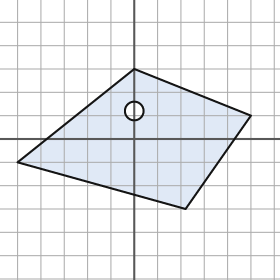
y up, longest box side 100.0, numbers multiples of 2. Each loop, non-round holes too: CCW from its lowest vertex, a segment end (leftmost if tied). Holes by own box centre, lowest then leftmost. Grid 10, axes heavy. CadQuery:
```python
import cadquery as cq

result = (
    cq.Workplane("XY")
    .moveTo(22.0, -30.0)
    .lineTo(50.0, 10.0)
    .lineTo(0.0, 30.0)
    .lineTo(-50.0, -10.0)
    .close()
    .moveTo(0.0, 12.0)
    .circle(4.0)
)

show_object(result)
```